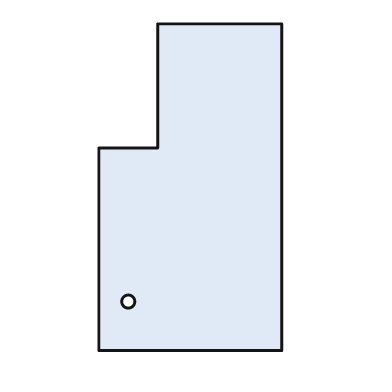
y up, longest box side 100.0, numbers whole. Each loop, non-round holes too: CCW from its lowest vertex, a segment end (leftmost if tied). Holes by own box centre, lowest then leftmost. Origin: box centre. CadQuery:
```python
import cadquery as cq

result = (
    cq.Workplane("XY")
    .moveTo(-28.0, -50.0)
    .lineTo(28.0, -50.0)
    .lineTo(28.0, 50.0)
    .lineTo(-10.0, 50.0)
    .lineTo(-10.0, 12.0)
    .lineTo(-28.0, 12.0)
    .close()
    .moveTo(-19.0, -35.0)
    .circle(2.0)
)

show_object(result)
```